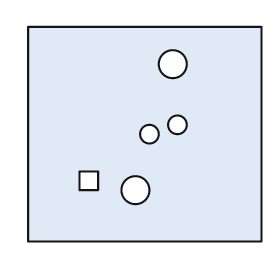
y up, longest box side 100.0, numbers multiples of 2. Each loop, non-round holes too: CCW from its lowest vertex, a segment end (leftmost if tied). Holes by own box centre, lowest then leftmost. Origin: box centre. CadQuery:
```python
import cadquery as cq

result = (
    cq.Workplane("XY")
    .moveTo(-50.0, -46.0)
    .lineTo(50.0, -46.0)
    .lineTo(50.0, 46.0)
    .lineTo(-50.0, 46.0)
    .close()
    .moveTo(-4.0, -24.0)
    .circle(6.0)
    .moveTo(-28.0, -24.0)
    .lineTo(-20.0, -24.0)
    .lineTo(-20.0, -16.0)
    .lineTo(-28.0, -16.0)
    .close()
    .moveTo(2.0, 0.0)
    .circle(4.0)
    .moveTo(14.0, 4.0)
    .circle(4.0)
    .moveTo(12.0, 30.0)
    .circle(6.0)
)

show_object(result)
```